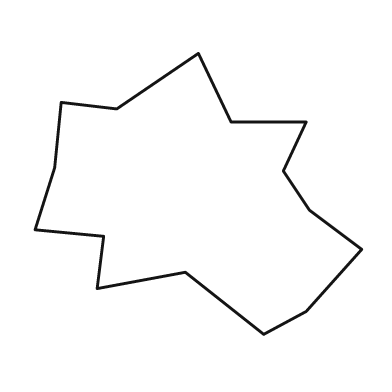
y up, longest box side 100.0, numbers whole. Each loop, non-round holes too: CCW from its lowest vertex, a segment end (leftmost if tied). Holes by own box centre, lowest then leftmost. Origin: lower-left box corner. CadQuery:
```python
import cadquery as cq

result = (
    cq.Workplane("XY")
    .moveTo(70.0, 0.0)
    .lineTo(83.0, 7.0)
    .lineTo(100.0, 26.0)
    .lineTo(84.0, 38.0)
    .lineTo(76.0, 50.0)
    .lineTo(83.0, 65.0)
    .lineTo(60.0, 65.0)
    .lineTo(50.0, 86.0)
    .lineTo(25.0, 69.0)
    .lineTo(8.0, 71.0)
    .lineTo(6.0, 51.0)
    .lineTo(0.0, 32.0)
    .lineTo(21.0, 30.0)
    .lineTo(19.0, 14.0)
    .lineTo(46.0, 19.0)
    .close()
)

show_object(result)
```